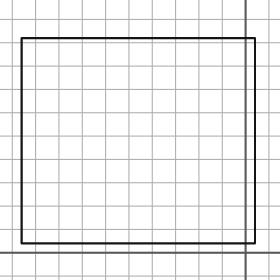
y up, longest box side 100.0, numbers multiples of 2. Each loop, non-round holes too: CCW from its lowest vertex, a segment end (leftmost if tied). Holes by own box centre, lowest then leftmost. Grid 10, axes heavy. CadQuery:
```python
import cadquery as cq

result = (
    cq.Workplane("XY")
    .moveTo(-96.0, 4.0)
    .lineTo(4.0, 4.0)
    .lineTo(4.0, 92.0)
    .lineTo(-96.0, 92.0)
    .close()
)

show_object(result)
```